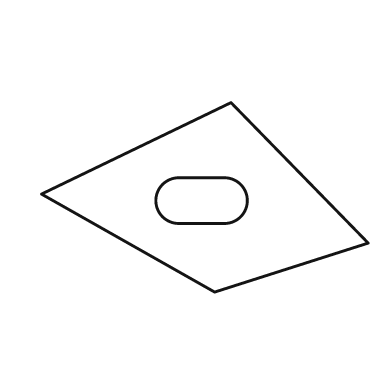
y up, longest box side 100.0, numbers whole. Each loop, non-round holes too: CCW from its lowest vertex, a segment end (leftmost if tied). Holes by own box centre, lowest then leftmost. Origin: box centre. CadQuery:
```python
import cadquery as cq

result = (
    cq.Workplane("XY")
    .moveTo(3.0, -29.0)
    .lineTo(50.0, -14.0)
    .lineTo(8.0, 29.0)
    .lineTo(-50.0, 1.0)
    .close()
    .moveTo(-8.0, -8.0)
    .lineTo(6.0, -8.0)
    .threePointArc((13.0, -1.0), (6.0, 6.0))
    .lineTo(-8.0, 6.0)
    .threePointArc((-15.0, -1.0), (-8.0, -8.0))
    .close()
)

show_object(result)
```